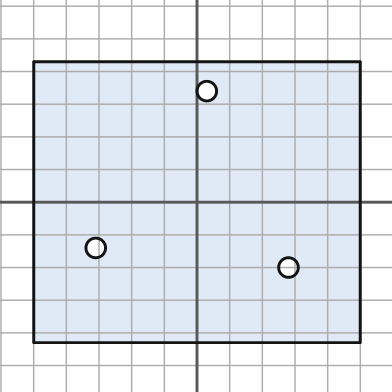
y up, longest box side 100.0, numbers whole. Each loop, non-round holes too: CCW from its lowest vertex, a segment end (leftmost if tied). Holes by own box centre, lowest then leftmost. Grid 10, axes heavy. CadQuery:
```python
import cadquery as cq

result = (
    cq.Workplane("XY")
    .moveTo(-50.0, -43.0)
    .lineTo(50.0, -43.0)
    .lineTo(50.0, 43.0)
    .lineTo(-50.0, 43.0)
    .close()
    .moveTo(28.0, -20.0)
    .circle(3.0)
    .moveTo(-31.0, -14.0)
    .circle(3.0)
    .moveTo(3.0, 34.0)
    .circle(3.0)
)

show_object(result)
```